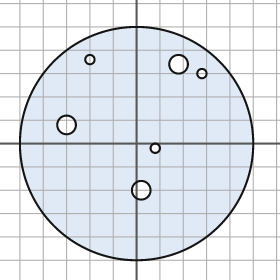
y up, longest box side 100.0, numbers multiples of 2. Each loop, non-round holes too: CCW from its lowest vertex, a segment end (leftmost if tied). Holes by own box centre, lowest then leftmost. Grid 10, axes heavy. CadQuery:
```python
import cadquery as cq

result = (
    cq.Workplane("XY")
    .moveTo(0.0, 0.0)
    .circle(50.0)
    .moveTo(2.0, -20.0)
    .circle(4.0)
    .moveTo(8.0, -2.0)
    .circle(2.0)
    .moveTo(-30.0, 8.0)
    .circle(4.0)
    .moveTo(28.0, 30.0)
    .circle(2.0)
    .moveTo(18.0, 34.0)
    .circle(4.0)
    .moveTo(-20.0, 36.0)
    .circle(2.0)
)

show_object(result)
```